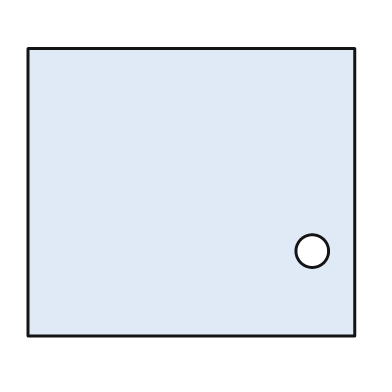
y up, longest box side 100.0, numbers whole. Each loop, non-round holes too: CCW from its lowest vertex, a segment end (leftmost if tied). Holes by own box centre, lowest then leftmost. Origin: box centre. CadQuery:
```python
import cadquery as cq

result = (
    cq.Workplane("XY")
    .moveTo(-50.0, -44.0)
    .lineTo(50.0, -44.0)
    .lineTo(50.0, 44.0)
    .lineTo(-50.0, 44.0)
    .close()
    .moveTo(37.0, -18.0)
    .circle(5.0)
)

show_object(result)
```